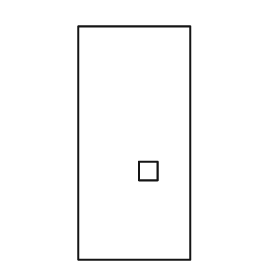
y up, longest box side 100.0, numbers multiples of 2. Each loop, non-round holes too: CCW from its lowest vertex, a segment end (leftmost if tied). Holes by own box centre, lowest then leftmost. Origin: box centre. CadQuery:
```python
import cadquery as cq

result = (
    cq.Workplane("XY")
    .moveTo(-24.0, -50.0)
    .lineTo(24.0, -50.0)
    .lineTo(24.0, 50.0)
    .lineTo(-24.0, 50.0)
    .close()
    .moveTo(2.0, -16.0)
    .lineTo(10.0, -16.0)
    .lineTo(10.0, -8.0)
    .lineTo(2.0, -8.0)
    .close()
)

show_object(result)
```